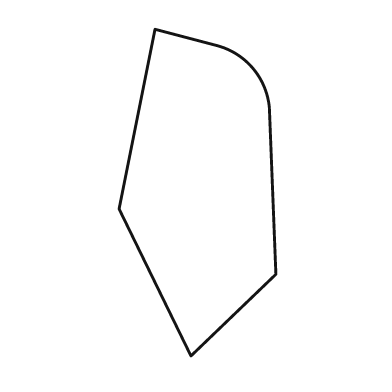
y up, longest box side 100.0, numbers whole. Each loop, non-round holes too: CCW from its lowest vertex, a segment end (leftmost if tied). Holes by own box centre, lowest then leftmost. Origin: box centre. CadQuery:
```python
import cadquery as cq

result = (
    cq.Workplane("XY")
    .moveTo(-2.0, -50.0)
    .lineTo(24.0, -25.0)
    .lineTo(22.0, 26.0)
    .threePointArc((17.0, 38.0), (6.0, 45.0))
    .lineTo(-13.0, 50.0)
    .lineTo(-24.0, -5.0)
    .close()
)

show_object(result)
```